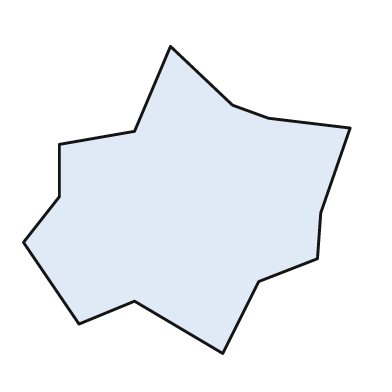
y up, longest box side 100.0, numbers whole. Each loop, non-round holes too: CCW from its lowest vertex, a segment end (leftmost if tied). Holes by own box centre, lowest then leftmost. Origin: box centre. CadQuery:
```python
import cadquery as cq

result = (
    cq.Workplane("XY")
    .moveTo(11.0, -47.0)
    .lineTo(22.0, -25.0)
    .lineTo(40.0, -18.0)
    .lineTo(41.0, -4.0)
    .lineTo(50.0, 22.0)
    .lineTo(25.0, 25.0)
    .lineTo(14.0, 29.0)
    .lineTo(-5.0, 47.0)
    .lineTo(-16.0, 21.0)
    .lineTo(-39.0, 17.0)
    .lineTo(-39.0, 1.0)
    .lineTo(-50.0, -13.0)
    .lineTo(-33.0, -38.0)
    .lineTo(-16.0, -31.0)
    .close()
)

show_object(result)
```